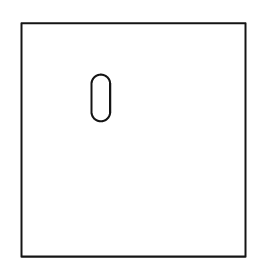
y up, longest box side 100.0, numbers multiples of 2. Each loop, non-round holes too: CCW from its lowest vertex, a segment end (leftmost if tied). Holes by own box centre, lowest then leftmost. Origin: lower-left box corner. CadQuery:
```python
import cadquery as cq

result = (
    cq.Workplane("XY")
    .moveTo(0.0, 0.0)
    .lineTo(96.0, 0.0)
    .lineTo(96.0, 100.0)
    .lineTo(0.0, 100.0)
    .close()
    .moveTo(30.0, 62.0)
    .threePointArc((34.0, 58.0), (38.0, 62.0))
    .lineTo(38.0, 74.0)
    .threePointArc((34.0, 78.0), (30.0, 74.0))
    .close()
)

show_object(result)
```